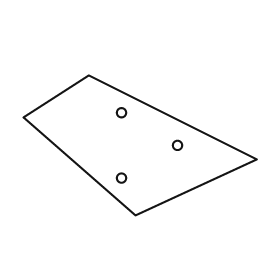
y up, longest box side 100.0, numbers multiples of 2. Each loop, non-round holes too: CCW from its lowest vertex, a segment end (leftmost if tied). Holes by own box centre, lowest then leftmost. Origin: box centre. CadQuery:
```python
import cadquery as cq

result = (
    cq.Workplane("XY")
    .moveTo(-2.0, -30.0)
    .lineTo(50.0, -6.0)
    .lineTo(-22.0, 30.0)
    .lineTo(-50.0, 12.0)
    .close()
    .moveTo(-8.0, -14.0)
    .circle(2.0)
    .moveTo(16.0, 0.0)
    .circle(2.0)
    .moveTo(-8.0, 14.0)
    .circle(2.0)
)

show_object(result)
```